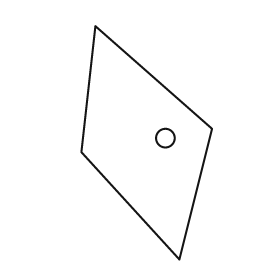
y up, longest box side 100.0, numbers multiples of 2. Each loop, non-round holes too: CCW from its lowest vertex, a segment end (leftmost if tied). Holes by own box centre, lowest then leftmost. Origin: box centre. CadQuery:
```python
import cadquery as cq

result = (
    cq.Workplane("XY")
    .moveTo(14.0, -50.0)
    .lineTo(28.0, 6.0)
    .lineTo(-22.0, 50.0)
    .lineTo(-28.0, -4.0)
    .close()
    .moveTo(8.0, 2.0)
    .circle(4.0)
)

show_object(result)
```